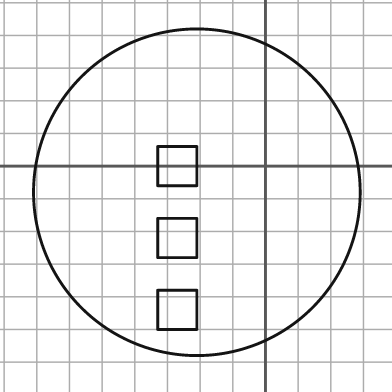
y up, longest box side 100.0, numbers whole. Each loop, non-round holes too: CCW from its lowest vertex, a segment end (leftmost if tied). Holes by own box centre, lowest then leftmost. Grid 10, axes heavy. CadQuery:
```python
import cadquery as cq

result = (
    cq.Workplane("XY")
    .moveTo(-21.0, -8.0)
    .circle(50.0)
    .moveTo(-33.0, -50.0)
    .lineTo(-21.0, -50.0)
    .lineTo(-21.0, -38.0)
    .lineTo(-33.0, -38.0)
    .close()
    .moveTo(-33.0, -28.0)
    .lineTo(-21.0, -28.0)
    .lineTo(-21.0, -16.0)
    .lineTo(-33.0, -16.0)
    .close()
    .moveTo(-33.0, -6.0)
    .lineTo(-21.0, -6.0)
    .lineTo(-21.0, 6.0)
    .lineTo(-33.0, 6.0)
    .close()
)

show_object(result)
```